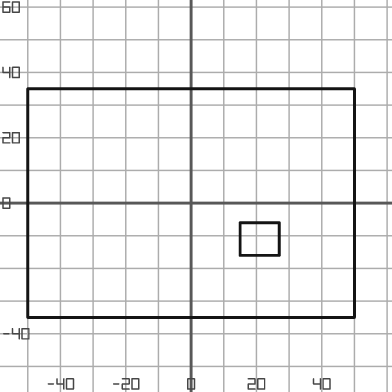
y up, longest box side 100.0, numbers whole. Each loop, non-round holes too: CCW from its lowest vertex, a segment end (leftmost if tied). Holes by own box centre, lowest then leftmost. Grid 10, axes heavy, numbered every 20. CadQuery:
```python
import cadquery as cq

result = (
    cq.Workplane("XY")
    .moveTo(-50.0, -35.0)
    .lineTo(50.0, -35.0)
    .lineTo(50.0, 35.0)
    .lineTo(-50.0, 35.0)
    .close()
    .moveTo(15.0, -16.0)
    .lineTo(27.0, -16.0)
    .lineTo(27.0, -6.0)
    .lineTo(15.0, -6.0)
    .close()
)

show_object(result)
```